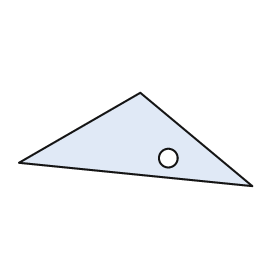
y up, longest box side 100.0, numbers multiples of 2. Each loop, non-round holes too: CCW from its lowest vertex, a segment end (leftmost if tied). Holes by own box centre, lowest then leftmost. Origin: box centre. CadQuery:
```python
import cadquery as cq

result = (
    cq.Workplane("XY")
    .moveTo(50.0, -20.0)
    .lineTo(2.0, 20.0)
    .lineTo(-50.0, -10.0)
    .close()
    .moveTo(14.0, -8.0)
    .circle(4.0)
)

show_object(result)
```